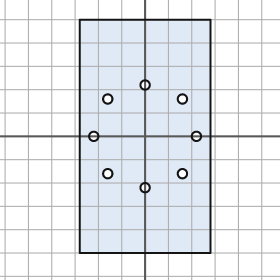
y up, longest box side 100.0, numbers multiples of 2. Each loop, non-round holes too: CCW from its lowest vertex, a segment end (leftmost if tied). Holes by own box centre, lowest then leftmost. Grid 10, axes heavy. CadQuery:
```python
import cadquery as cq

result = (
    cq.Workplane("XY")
    .moveTo(-28.0, -50.0)
    .lineTo(28.0, -50.0)
    .lineTo(28.0, 50.0)
    .lineTo(-28.0, 50.0)
    .close()
    .moveTo(0.0, -22.0)
    .circle(2.0)
    .moveTo(-16.0, -16.0)
    .circle(2.0)
    .moveTo(16.0, -16.0)
    .circle(2.0)
    .moveTo(-22.0, 0.0)
    .circle(2.0)
    .moveTo(22.0, 0.0)
    .circle(2.0)
    .moveTo(-16.0, 16.0)
    .circle(2.0)
    .moveTo(16.0, 16.0)
    .circle(2.0)
    .moveTo(0.0, 22.0)
    .circle(2.0)
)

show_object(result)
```